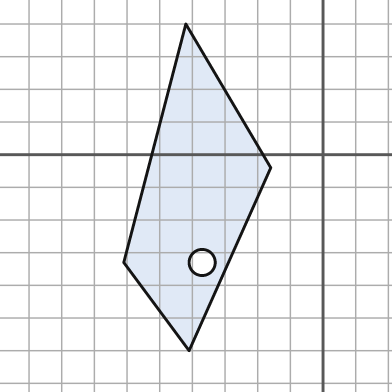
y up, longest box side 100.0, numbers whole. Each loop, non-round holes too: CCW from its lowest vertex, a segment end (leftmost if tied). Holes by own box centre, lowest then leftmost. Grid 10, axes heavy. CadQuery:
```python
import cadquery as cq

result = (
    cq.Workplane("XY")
    .moveTo(-41.0, -60.0)
    .lineTo(-16.0, -4.0)
    .lineTo(-42.0, 40.0)
    .lineTo(-61.0, -33.0)
    .close()
    .moveTo(-37.0, -33.0)
    .circle(4.0)
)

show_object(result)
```